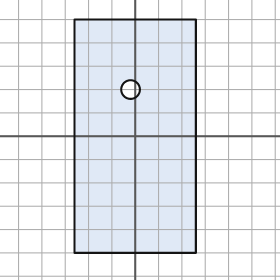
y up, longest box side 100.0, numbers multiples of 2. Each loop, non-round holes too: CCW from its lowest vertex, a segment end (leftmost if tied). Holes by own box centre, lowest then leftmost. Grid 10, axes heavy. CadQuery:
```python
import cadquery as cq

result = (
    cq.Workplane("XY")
    .moveTo(-26.0, -50.0)
    .lineTo(26.0, -50.0)
    .lineTo(26.0, 50.0)
    .lineTo(-26.0, 50.0)
    .close()
    .moveTo(-2.0, 20.0)
    .circle(4.0)
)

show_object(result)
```